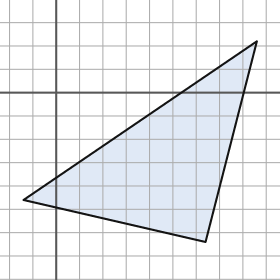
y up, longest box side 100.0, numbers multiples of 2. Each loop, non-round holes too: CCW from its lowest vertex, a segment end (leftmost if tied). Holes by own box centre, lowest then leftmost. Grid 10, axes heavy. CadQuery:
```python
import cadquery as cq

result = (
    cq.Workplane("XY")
    .moveTo(64.0, -64.0)
    .lineTo(86.0, 22.0)
    .lineTo(-14.0, -46.0)
    .close()
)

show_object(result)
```